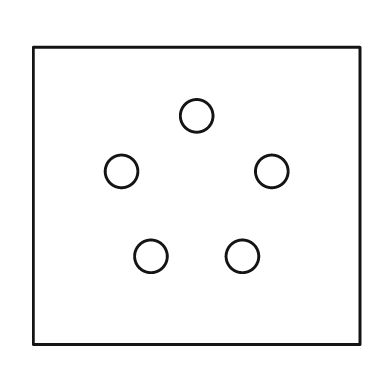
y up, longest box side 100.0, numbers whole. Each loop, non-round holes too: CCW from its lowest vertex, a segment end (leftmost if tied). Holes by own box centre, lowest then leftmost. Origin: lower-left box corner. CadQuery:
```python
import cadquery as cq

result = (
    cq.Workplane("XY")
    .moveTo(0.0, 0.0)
    .lineTo(100.0, 0.0)
    .lineTo(100.0, 91.0)
    .lineTo(0.0, 91.0)
    .close()
    .moveTo(36.0, 27.0)
    .circle(5.0)
    .moveTo(64.0, 27.0)
    .circle(5.0)
    .moveTo(27.0, 53.0)
    .circle(5.0)
    .moveTo(73.0, 53.0)
    .circle(5.0)
    .moveTo(50.0, 70.0)
    .circle(5.0)
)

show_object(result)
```